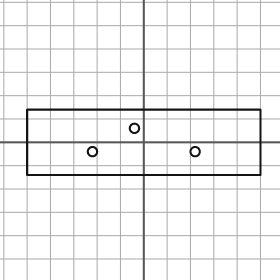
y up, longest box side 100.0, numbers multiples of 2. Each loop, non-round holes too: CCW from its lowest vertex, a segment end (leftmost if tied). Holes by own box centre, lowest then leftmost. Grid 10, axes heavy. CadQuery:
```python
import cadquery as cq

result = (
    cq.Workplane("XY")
    .moveTo(-50.0, -14.0)
    .lineTo(50.0, -14.0)
    .lineTo(50.0, 14.0)
    .lineTo(-50.0, 14.0)
    .close()
    .moveTo(-22.0, -4.0)
    .circle(2.0)
    .moveTo(22.0, -4.0)
    .circle(2.0)
    .moveTo(-4.0, 6.0)
    .circle(2.0)
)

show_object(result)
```